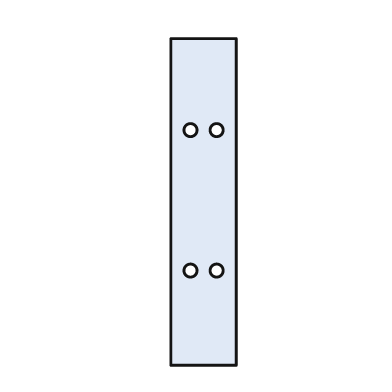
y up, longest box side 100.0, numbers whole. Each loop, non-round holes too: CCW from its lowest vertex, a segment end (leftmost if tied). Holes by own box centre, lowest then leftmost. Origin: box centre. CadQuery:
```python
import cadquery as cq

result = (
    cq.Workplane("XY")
    .moveTo(-10.0, -50.0)
    .lineTo(10.0, -50.0)
    .lineTo(10.0, 50.0)
    .lineTo(-10.0, 50.0)
    .close()
    .moveTo(-4.0, -21.0)
    .circle(2.0)
    .moveTo(4.0, -21.0)
    .circle(2.0)
    .moveTo(-4.0, 22.0)
    .circle(2.0)
    .moveTo(4.0, 22.0)
    .circle(2.0)
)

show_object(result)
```